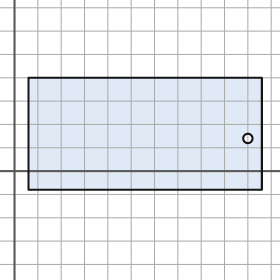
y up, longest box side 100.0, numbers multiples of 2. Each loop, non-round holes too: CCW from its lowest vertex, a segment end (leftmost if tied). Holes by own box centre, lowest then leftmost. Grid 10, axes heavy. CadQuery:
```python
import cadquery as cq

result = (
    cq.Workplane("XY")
    .moveTo(6.0, -8.0)
    .lineTo(106.0, -8.0)
    .lineTo(106.0, 40.0)
    .lineTo(6.0, 40.0)
    .close()
    .moveTo(100.0, 14.0)
    .circle(2.0)
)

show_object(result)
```